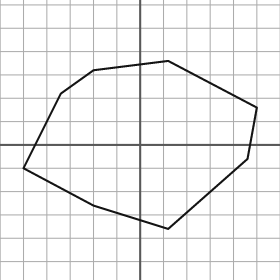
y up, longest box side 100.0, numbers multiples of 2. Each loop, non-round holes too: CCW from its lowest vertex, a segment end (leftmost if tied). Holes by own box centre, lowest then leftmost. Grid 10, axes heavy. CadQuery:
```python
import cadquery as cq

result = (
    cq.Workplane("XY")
    .moveTo(12.0, -36.0)
    .lineTo(46.0, -6.0)
    .lineTo(50.0, 16.0)
    .lineTo(12.0, 36.0)
    .lineTo(-20.0, 32.0)
    .lineTo(-34.0, 22.0)
    .lineTo(-50.0, -10.0)
    .lineTo(-20.0, -26.0)
    .close()
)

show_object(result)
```